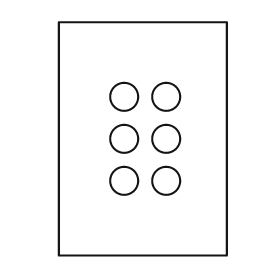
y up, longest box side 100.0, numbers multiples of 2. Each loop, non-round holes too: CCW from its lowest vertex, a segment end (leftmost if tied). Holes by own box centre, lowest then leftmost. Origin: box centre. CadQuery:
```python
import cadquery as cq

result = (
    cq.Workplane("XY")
    .moveTo(-36.0, -50.0)
    .lineTo(36.0, -50.0)
    .lineTo(36.0, 50.0)
    .lineTo(-36.0, 50.0)
    .close()
    .moveTo(-8.0, -18.0)
    .circle(6.0)
    .moveTo(10.0, -18.0)
    .circle(6.0)
    .moveTo(-8.0, 0.0)
    .circle(6.0)
    .moveTo(10.0, 0.0)
    .circle(6.0)
    .moveTo(-8.0, 18.0)
    .circle(6.0)
    .moveTo(10.0, 18.0)
    .circle(6.0)
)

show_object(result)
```